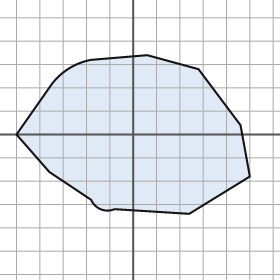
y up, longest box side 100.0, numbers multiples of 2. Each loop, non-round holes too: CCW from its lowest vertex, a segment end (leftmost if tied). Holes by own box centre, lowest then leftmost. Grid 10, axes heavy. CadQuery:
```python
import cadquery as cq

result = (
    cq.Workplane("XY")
    .moveTo(24.0, -34.0)
    .lineTo(50.0, -18.0)
    .lineTo(46.0, 4.0)
    .lineTo(28.0, 28.0)
    .lineTo(6.0, 34.0)
    .lineTo(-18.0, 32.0)
    .threePointArc((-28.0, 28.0), (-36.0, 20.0))
    .lineTo(-50.0, 0.0)
    .lineTo(-36.0, -16.0)
    .lineTo(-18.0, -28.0)
    .threePointArc((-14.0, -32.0), (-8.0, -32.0))
    .close()
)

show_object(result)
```